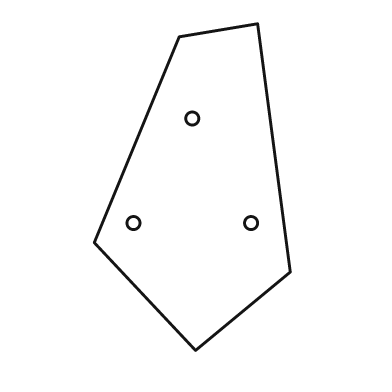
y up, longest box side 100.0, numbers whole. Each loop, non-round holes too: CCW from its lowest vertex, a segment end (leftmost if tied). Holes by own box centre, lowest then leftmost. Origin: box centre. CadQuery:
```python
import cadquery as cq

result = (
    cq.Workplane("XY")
    .moveTo(1.0, -50.0)
    .lineTo(30.0, -26.0)
    .lineTo(20.0, 50.0)
    .lineTo(-4.0, 46.0)
    .lineTo(-30.0, -17.0)
    .close()
    .moveTo(-18.0, -11.0)
    .circle(2.0)
    .moveTo(18.0, -11.0)
    .circle(2.0)
    .moveTo(0.0, 21.0)
    .circle(2.0)
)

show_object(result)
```